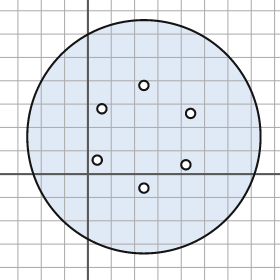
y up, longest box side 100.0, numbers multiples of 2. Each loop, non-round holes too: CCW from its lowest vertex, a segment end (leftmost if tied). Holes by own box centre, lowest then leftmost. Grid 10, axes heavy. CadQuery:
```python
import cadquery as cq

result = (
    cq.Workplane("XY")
    .moveTo(24.0, 16.0)
    .circle(50.0)
    .moveTo(24.0, -6.0)
    .circle(2.0)
    .moveTo(42.0, 4.0)
    .circle(2.0)
    .moveTo(4.0, 6.0)
    .circle(2.0)
    .moveTo(44.0, 26.0)
    .circle(2.0)
    .moveTo(6.0, 28.0)
    .circle(2.0)
    .moveTo(24.0, 38.0)
    .circle(2.0)
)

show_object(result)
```